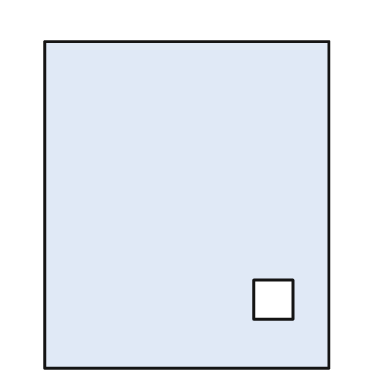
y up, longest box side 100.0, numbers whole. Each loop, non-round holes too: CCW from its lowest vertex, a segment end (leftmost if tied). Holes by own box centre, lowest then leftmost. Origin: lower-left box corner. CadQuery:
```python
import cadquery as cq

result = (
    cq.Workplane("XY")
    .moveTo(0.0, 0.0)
    .lineTo(87.0, 0.0)
    .lineTo(87.0, 100.0)
    .lineTo(0.0, 100.0)
    .close()
    .moveTo(64.0, 15.0)
    .lineTo(76.0, 15.0)
    .lineTo(76.0, 27.0)
    .lineTo(64.0, 27.0)
    .close()
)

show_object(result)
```